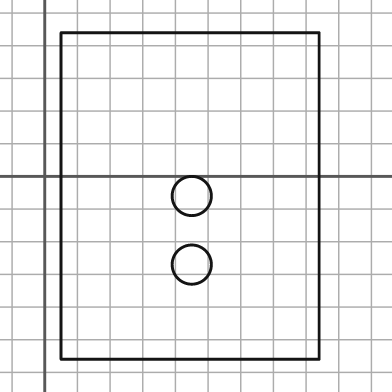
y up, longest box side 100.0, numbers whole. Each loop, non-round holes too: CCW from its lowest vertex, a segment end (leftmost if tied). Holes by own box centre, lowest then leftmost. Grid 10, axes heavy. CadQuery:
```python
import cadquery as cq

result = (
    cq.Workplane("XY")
    .moveTo(5.0, -56.0)
    .lineTo(84.0, -56.0)
    .lineTo(84.0, 44.0)
    .lineTo(5.0, 44.0)
    .close()
    .moveTo(45.0, -27.0)
    .circle(6.0)
    .moveTo(45.0, -6.0)
    .circle(6.0)
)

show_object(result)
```